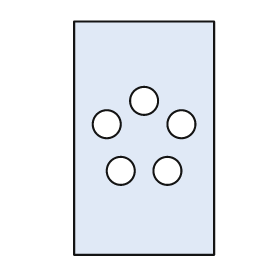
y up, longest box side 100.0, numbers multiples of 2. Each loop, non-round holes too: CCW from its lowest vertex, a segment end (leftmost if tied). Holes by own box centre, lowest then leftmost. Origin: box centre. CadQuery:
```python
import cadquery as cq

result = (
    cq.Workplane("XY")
    .moveTo(-30.0, -50.0)
    .lineTo(30.0, -50.0)
    .lineTo(30.0, 50.0)
    .lineTo(-30.0, 50.0)
    .close()
    .moveTo(-10.0, -14.0)
    .circle(6.0)
    .moveTo(10.0, -14.0)
    .circle(6.0)
    .moveTo(-16.0, 6.0)
    .circle(6.0)
    .moveTo(16.0, 6.0)
    .circle(6.0)
    .moveTo(0.0, 16.0)
    .circle(6.0)
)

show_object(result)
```